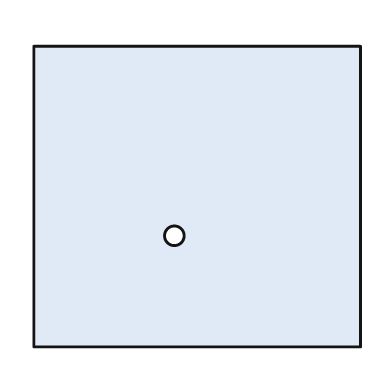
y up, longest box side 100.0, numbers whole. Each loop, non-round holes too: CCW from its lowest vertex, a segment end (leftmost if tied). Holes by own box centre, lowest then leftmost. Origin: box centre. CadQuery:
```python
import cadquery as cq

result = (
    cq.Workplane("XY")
    .moveTo(-50.0, -46.0)
    .lineTo(50.0, -46.0)
    .lineTo(50.0, 46.0)
    .lineTo(-50.0, 46.0)
    .close()
    .moveTo(-7.0, -12.0)
    .circle(3.0)
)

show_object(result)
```